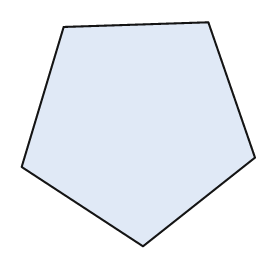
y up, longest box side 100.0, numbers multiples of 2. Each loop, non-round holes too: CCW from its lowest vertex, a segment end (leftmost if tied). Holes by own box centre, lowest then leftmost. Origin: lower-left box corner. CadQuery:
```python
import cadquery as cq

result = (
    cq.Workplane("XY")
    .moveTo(52.0, 0.0)
    .lineTo(100.0, 38.0)
    .lineTo(80.0, 96.0)
    .lineTo(18.0, 94.0)
    .lineTo(0.0, 34.0)
    .close()
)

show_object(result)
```